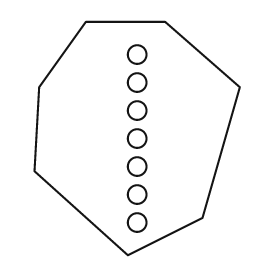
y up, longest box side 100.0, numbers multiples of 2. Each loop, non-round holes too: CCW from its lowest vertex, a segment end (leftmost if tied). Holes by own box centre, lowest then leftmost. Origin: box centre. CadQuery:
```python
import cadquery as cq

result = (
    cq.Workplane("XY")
    .moveTo(-4.0, -50.0)
    .lineTo(28.0, -34.0)
    .lineTo(44.0, 22.0)
    .lineTo(12.0, 50.0)
    .lineTo(-22.0, 50.0)
    .lineTo(-42.0, 22.0)
    .lineTo(-44.0, -14.0)
    .close()
    .moveTo(0.0, -36.0)
    .circle(4.0)
    .moveTo(0.0, -24.0)
    .circle(4.0)
    .moveTo(0.0, -12.0)
    .circle(4.0)
    .moveTo(0.0, 0.0)
    .circle(4.0)
    .moveTo(0.0, 12.0)
    .circle(4.0)
    .moveTo(0.0, 24.0)
    .circle(4.0)
    .moveTo(0.0, 36.0)
    .circle(4.0)
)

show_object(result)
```